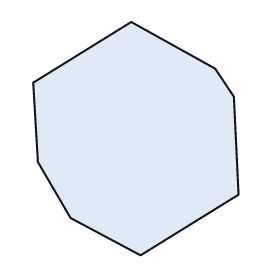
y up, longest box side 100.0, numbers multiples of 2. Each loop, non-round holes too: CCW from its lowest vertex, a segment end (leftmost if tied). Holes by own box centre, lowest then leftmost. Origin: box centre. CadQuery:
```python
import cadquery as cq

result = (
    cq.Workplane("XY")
    .moveTo(2.0, -50.0)
    .lineTo(44.0, -24.0)
    .lineTo(42.0, 18.0)
    .lineTo(34.0, 30.0)
    .lineTo(-2.0, 50.0)
    .lineTo(-44.0, 24.0)
    .lineTo(-42.0, -10.0)
    .lineTo(-28.0, -34.0)
    .close()
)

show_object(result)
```